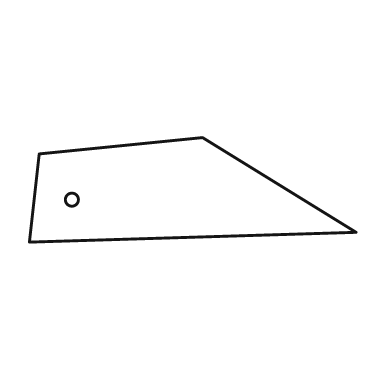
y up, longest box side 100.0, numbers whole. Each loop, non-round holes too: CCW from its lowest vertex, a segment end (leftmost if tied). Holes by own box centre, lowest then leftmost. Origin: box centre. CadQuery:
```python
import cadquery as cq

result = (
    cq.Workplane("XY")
    .moveTo(-50.0, -16.0)
    .lineTo(50.0, -13.0)
    .lineTo(3.0, 16.0)
    .lineTo(-47.0, 11.0)
    .close()
    .moveTo(-37.0, -3.0)
    .circle(2.0)
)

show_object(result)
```